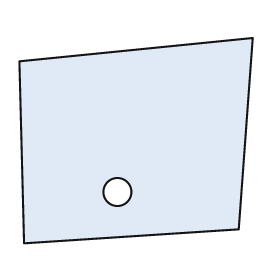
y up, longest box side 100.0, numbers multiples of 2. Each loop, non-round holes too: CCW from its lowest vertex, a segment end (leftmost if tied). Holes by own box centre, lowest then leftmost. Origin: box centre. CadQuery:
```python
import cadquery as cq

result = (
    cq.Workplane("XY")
    .moveTo(-48.0, -44.0)
    .lineTo(44.0, -38.0)
    .lineTo(50.0, 44.0)
    .lineTo(-50.0, 34.0)
    .close()
    .moveTo(-8.0, -22.0)
    .circle(6.0)
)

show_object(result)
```